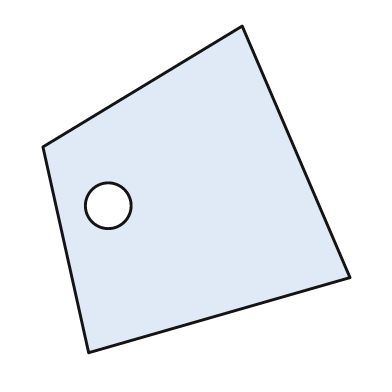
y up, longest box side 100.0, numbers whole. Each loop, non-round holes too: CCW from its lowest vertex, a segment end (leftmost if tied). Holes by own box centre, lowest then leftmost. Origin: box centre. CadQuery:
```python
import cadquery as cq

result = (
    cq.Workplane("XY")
    .moveTo(-33.0, -50.0)
    .lineTo(47.0, -27.0)
    .lineTo(14.0, 50.0)
    .lineTo(-47.0, 13.0)
    .close()
    .moveTo(-27.0, -5.0)
    .circle(7.0)
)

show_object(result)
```